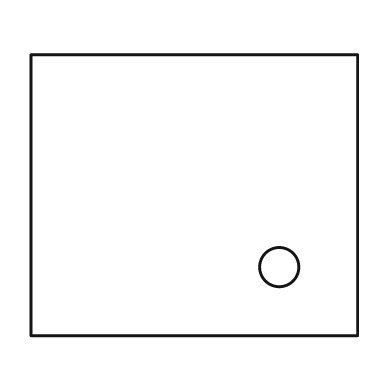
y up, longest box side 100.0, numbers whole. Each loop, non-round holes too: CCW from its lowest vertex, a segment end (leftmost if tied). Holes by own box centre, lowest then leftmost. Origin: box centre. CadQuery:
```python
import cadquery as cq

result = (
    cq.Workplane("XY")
    .moveTo(-50.0, -43.0)
    .lineTo(50.0, -43.0)
    .lineTo(50.0, 43.0)
    .lineTo(-50.0, 43.0)
    .close()
    .moveTo(26.0, -22.0)
    .circle(6.0)
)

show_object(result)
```